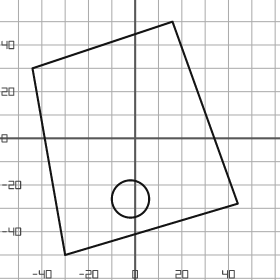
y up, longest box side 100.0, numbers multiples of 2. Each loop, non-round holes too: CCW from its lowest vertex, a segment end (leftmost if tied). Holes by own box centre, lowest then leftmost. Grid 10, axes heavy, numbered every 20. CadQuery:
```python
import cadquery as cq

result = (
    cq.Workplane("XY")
    .moveTo(-30.0, -50.0)
    .lineTo(44.0, -28.0)
    .lineTo(16.0, 50.0)
    .lineTo(-44.0, 30.0)
    .close()
    .moveTo(-2.0, -26.0)
    .circle(8.0)
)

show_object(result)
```